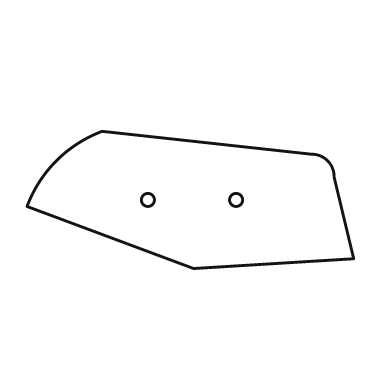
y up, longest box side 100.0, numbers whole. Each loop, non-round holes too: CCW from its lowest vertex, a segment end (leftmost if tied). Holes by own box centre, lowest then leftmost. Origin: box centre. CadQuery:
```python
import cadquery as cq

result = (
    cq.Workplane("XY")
    .moveTo(1.0, -21.0)
    .lineTo(50.0, -18.0)
    .lineTo(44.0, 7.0)
    .threePointArc((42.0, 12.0), (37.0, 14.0))
    .lineTo(-27.0, 21.0)
    .threePointArc((-41.0, 12.0), (-50.0, -2.0))
    .close()
    .moveTo(-13.0, 0.0)
    .circle(2.0)
    .moveTo(14.0, 0.0)
    .circle(2.0)
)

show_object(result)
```